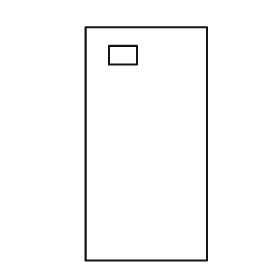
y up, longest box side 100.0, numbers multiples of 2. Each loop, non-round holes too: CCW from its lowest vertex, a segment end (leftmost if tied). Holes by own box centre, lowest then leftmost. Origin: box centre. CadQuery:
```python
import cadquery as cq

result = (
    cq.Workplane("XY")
    .moveTo(-26.0, -50.0)
    .lineTo(26.0, -50.0)
    .lineTo(26.0, 50.0)
    .lineTo(-26.0, 50.0)
    .close()
    .moveTo(-16.0, 34.0)
    .lineTo(-4.0, 34.0)
    .lineTo(-4.0, 42.0)
    .lineTo(-16.0, 42.0)
    .close()
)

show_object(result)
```